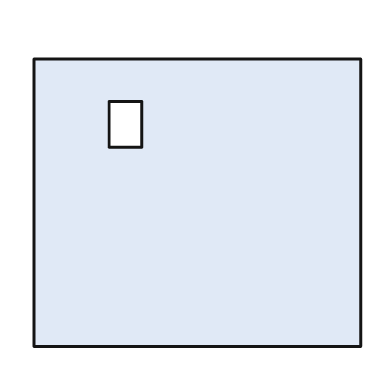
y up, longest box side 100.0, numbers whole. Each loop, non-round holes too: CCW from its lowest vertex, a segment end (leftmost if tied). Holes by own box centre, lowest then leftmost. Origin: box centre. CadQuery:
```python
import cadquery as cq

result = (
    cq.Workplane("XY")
    .moveTo(-50.0, -44.0)
    .lineTo(50.0, -44.0)
    .lineTo(50.0, 44.0)
    .lineTo(-50.0, 44.0)
    .close()
    .moveTo(-27.0, 17.0)
    .lineTo(-17.0, 17.0)
    .lineTo(-17.0, 31.0)
    .lineTo(-27.0, 31.0)
    .close()
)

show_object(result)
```